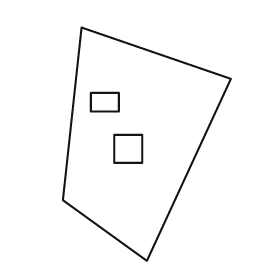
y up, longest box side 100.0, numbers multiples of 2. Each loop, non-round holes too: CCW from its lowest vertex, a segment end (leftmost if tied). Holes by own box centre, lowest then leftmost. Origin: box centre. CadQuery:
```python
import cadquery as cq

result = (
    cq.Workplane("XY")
    .moveTo(0.0, -50.0)
    .lineTo(36.0, 28.0)
    .lineTo(-28.0, 50.0)
    .lineTo(-36.0, -24.0)
    .close()
    .moveTo(-14.0, -8.0)
    .lineTo(-2.0, -8.0)
    .lineTo(-2.0, 4.0)
    .lineTo(-14.0, 4.0)
    .close()
    .moveTo(-24.0, 14.0)
    .lineTo(-12.0, 14.0)
    .lineTo(-12.0, 22.0)
    .lineTo(-24.0, 22.0)
    .close()
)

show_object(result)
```